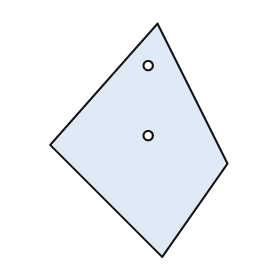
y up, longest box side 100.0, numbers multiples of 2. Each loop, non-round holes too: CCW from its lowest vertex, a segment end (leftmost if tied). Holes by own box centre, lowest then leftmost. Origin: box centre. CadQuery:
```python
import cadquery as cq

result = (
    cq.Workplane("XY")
    .moveTo(10.0, -50.0)
    .lineTo(38.0, -10.0)
    .lineTo(8.0, 50.0)
    .lineTo(-38.0, -2.0)
    .close()
    .moveTo(4.0, 2.0)
    .circle(2.0)
    .moveTo(4.0, 32.0)
    .circle(2.0)
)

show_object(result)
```